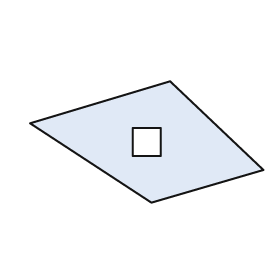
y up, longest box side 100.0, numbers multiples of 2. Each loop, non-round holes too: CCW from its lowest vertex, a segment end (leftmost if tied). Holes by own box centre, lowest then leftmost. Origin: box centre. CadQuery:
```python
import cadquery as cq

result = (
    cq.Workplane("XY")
    .moveTo(2.0, -26.0)
    .lineTo(50.0, -12.0)
    .lineTo(10.0, 26.0)
    .lineTo(-50.0, 8.0)
    .close()
    .moveTo(-6.0, -6.0)
    .lineTo(6.0, -6.0)
    .lineTo(6.0, 6.0)
    .lineTo(-6.0, 6.0)
    .close()
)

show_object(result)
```